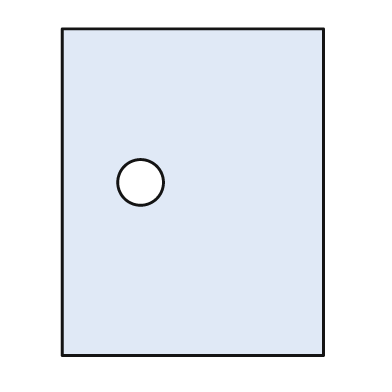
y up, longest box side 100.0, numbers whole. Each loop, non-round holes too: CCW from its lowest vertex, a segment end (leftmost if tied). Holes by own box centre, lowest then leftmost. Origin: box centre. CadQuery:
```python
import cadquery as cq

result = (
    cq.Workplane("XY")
    .moveTo(-40.0, -50.0)
    .lineTo(40.0, -50.0)
    .lineTo(40.0, 50.0)
    .lineTo(-40.0, 50.0)
    .close()
    .moveTo(-16.0, 3.0)
    .circle(7.0)
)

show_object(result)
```